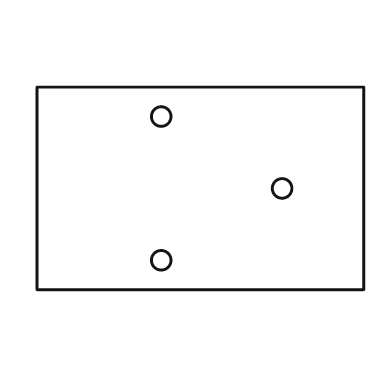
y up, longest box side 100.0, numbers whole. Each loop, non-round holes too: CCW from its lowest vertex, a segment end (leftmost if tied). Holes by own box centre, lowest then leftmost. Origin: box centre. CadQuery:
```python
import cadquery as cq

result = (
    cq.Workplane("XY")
    .moveTo(-50.0, -31.0)
    .lineTo(50.0, -31.0)
    .lineTo(50.0, 31.0)
    .lineTo(-50.0, 31.0)
    .close()
    .moveTo(-12.0, -22.0)
    .circle(3.0)
    .moveTo(25.0, 0.0)
    .circle(3.0)
    .moveTo(-12.0, 22.0)
    .circle(3.0)
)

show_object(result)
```